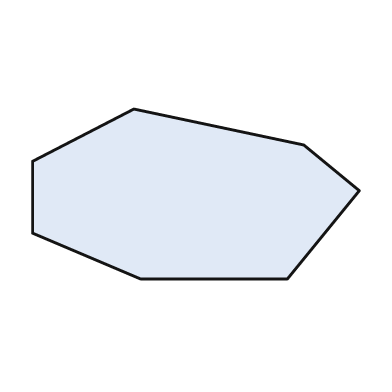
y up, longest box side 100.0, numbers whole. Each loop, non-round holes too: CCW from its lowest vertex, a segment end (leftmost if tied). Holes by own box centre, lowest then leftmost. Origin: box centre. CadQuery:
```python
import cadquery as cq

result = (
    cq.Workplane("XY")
    .moveTo(-17.0, -26.0)
    .lineTo(28.0, -26.0)
    .lineTo(50.0, 1.0)
    .lineTo(33.0, 15.0)
    .lineTo(-19.0, 26.0)
    .lineTo(-50.0, 10.0)
    .lineTo(-50.0, -12.0)
    .close()
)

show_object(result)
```